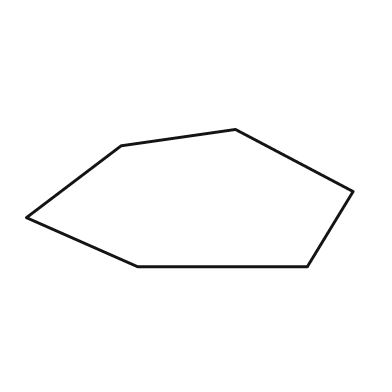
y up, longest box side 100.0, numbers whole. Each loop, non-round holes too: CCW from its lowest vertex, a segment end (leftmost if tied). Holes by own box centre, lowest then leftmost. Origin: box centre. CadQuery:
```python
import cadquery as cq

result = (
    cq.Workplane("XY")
    .moveTo(-16.0, -21.0)
    .lineTo(36.0, -21.0)
    .lineTo(50.0, 2.0)
    .lineTo(14.0, 21.0)
    .lineTo(-21.0, 16.0)
    .lineTo(-50.0, -6.0)
    .close()
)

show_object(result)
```